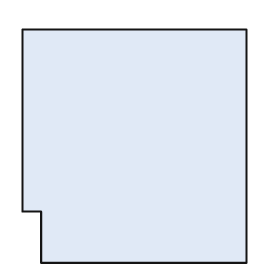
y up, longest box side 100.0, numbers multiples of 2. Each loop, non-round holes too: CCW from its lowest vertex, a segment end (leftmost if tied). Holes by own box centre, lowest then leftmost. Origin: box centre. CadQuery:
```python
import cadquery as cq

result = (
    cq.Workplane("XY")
    .moveTo(-40.0, -50.0)
    .lineTo(48.0, -50.0)
    .lineTo(48.0, 50.0)
    .lineTo(-48.0, 50.0)
    .lineTo(-48.0, -28.0)
    .lineTo(-40.0, -28.0)
    .close()
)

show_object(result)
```